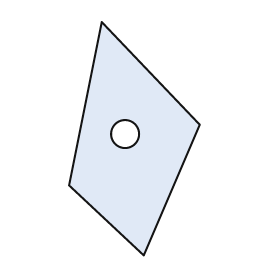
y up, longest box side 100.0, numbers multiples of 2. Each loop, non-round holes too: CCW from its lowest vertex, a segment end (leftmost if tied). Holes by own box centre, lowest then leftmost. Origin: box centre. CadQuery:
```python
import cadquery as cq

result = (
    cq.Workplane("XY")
    .moveTo(4.0, -50.0)
    .lineTo(28.0, 6.0)
    .lineTo(-14.0, 50.0)
    .lineTo(-28.0, -20.0)
    .close()
    .moveTo(-4.0, 2.0)
    .circle(6.0)
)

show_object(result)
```